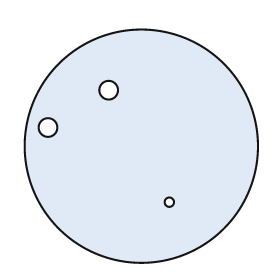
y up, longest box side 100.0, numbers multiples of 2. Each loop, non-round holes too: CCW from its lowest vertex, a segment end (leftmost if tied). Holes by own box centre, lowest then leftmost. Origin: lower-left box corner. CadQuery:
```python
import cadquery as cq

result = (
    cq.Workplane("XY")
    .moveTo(50.0, 50.0)
    .circle(50.0)
    .moveTo(62.0, 26.0)
    .circle(2.0)
    .moveTo(10.0, 58.0)
    .circle(4.0)
    .moveTo(36.0, 74.0)
    .circle(4.0)
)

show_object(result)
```